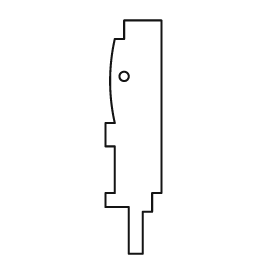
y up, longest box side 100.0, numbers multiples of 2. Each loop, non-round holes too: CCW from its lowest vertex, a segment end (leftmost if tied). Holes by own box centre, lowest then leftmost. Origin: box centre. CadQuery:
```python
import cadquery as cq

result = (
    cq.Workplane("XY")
    .moveTo(-2.0, -50.0)
    .lineTo(4.0, -50.0)
    .lineTo(4.0, -32.0)
    .lineTo(8.0, -32.0)
    .lineTo(8.0, -24.0)
    .lineTo(12.0, -24.0)
    .lineTo(12.0, 50.0)
    .lineTo(-4.0, 50.0)
    .lineTo(-4.0, 42.0)
    .lineTo(-8.0, 42.0)
    .threePointArc((-10.0, 24.0), (-8.0, 6.0))
    .lineTo(-12.0, 6.0)
    .lineTo(-12.0, -4.0)
    .lineTo(-8.0, -4.0)
    .lineTo(-8.0, -24.0)
    .lineTo(-12.0, -24.0)
    .lineTo(-12.0, -30.0)
    .lineTo(-2.0, -30.0)
    .close()
    .moveTo(-4.0, 26.0)
    .circle(2.0)
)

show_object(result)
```